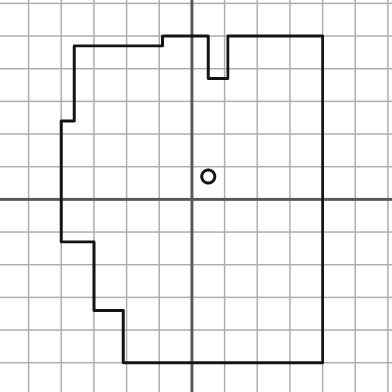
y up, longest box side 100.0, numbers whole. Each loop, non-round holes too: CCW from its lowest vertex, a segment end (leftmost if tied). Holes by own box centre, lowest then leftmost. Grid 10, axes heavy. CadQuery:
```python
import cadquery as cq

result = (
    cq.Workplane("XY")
    .moveTo(-21.0, -50.0)
    .lineTo(40.0, -50.0)
    .lineTo(40.0, 50.0)
    .lineTo(11.0, 50.0)
    .lineTo(11.0, 37.0)
    .lineTo(5.0, 37.0)
    .lineTo(5.0, 50.0)
    .lineTo(-9.0, 50.0)
    .lineTo(-9.0, 47.0)
    .lineTo(-36.0, 47.0)
    .lineTo(-36.0, 24.0)
    .lineTo(-40.0, 24.0)
    .lineTo(-40.0, -13.0)
    .lineTo(-30.0, -13.0)
    .lineTo(-30.0, -34.0)
    .lineTo(-21.0, -34.0)
    .close()
    .moveTo(5.0, 7.0)
    .circle(2.0)
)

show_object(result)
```